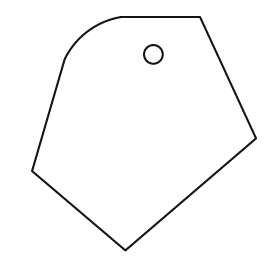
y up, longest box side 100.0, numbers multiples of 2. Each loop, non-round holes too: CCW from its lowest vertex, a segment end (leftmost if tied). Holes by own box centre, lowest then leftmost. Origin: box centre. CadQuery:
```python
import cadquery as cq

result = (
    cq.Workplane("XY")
    .moveTo(-8.0, -50.0)
    .lineTo(48.0, -2.0)
    .lineTo(24.0, 50.0)
    .lineTo(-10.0, 50.0)
    .threePointArc((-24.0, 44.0), (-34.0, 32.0))
    .lineTo(-48.0, -16.0)
    .close()
    .moveTo(4.0, 34.0)
    .circle(4.0)
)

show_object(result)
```